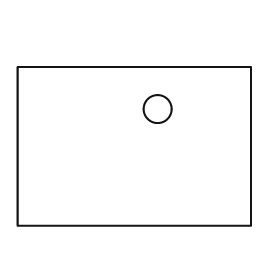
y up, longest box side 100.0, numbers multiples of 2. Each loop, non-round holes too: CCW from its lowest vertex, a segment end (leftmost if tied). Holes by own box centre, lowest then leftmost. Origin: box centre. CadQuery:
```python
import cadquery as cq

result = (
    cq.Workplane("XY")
    .moveTo(-50.0, -34.0)
    .lineTo(50.0, -34.0)
    .lineTo(50.0, 34.0)
    .lineTo(-50.0, 34.0)
    .close()
    .moveTo(10.0, 16.0)
    .circle(6.0)
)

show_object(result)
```